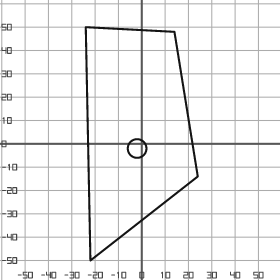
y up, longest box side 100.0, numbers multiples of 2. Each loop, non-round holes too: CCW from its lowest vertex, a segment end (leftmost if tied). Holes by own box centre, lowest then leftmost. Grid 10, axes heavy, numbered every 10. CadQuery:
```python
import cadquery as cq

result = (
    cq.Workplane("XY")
    .moveTo(-22.0, -50.0)
    .lineTo(24.0, -14.0)
    .lineTo(14.0, 48.0)
    .lineTo(-24.0, 50.0)
    .close()
    .moveTo(-2.0, -2.0)
    .circle(4.0)
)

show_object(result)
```